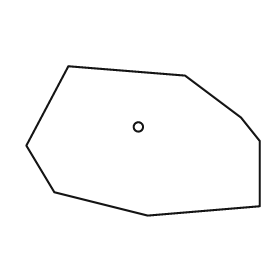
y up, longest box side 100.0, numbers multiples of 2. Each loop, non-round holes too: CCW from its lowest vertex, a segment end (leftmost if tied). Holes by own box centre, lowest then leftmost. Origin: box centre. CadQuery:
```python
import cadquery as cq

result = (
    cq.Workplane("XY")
    .moveTo(2.0, -32.0)
    .lineTo(50.0, -28.0)
    .lineTo(50.0, 0.0)
    .lineTo(42.0, 10.0)
    .lineTo(18.0, 28.0)
    .lineTo(-32.0, 32.0)
    .lineTo(-50.0, -2.0)
    .lineTo(-38.0, -22.0)
    .close()
    .moveTo(-2.0, 6.0)
    .circle(2.0)
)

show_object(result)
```